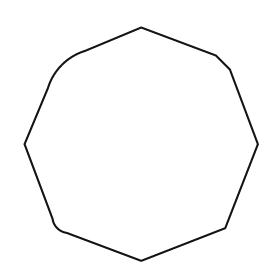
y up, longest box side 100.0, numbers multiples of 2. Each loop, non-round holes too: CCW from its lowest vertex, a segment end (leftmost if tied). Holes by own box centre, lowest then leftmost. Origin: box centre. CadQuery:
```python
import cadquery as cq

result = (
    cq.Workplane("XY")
    .moveTo(0.0, -50.0)
    .lineTo(36.0, -36.0)
    .lineTo(50.0, 0.0)
    .lineTo(38.0, 32.0)
    .lineTo(32.0, 38.0)
    .lineTo(0.0, 50.0)
    .lineTo(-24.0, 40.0)
    .threePointArc((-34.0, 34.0), (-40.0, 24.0))
    .lineTo(-50.0, 0.0)
    .lineTo(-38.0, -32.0)
    .threePointArc((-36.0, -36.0), (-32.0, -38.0))
    .close()
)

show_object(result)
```